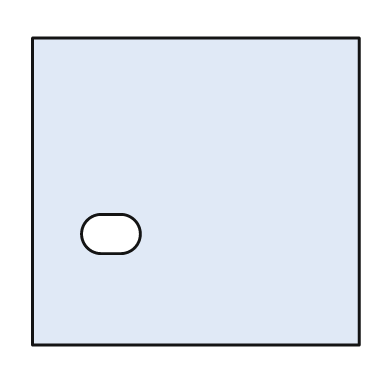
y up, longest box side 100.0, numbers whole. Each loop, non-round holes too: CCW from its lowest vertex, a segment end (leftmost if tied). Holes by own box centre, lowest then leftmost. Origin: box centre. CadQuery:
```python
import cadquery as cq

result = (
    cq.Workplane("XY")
    .moveTo(-50.0, -47.0)
    .lineTo(50.0, -47.0)
    .lineTo(50.0, 47.0)
    .lineTo(-50.0, 47.0)
    .close()
    .moveTo(-29.0, -19.0)
    .lineTo(-23.0, -19.0)
    .threePointArc((-17.0, -13.0), (-23.0, -7.0))
    .lineTo(-29.0, -7.0)
    .threePointArc((-35.0, -13.0), (-29.0, -19.0))
    .close()
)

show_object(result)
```